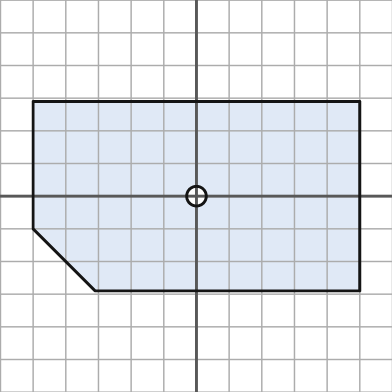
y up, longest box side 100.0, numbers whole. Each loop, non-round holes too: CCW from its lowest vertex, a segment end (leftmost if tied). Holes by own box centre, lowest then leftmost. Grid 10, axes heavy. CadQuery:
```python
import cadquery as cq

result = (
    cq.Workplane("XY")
    .moveTo(-31.0, -29.0)
    .lineTo(50.0, -29.0)
    .lineTo(50.0, 29.0)
    .lineTo(-50.0, 29.0)
    .lineTo(-50.0, -10.0)
    .close()
    .moveTo(0.0, 0.0)
    .circle(3.0)
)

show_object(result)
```